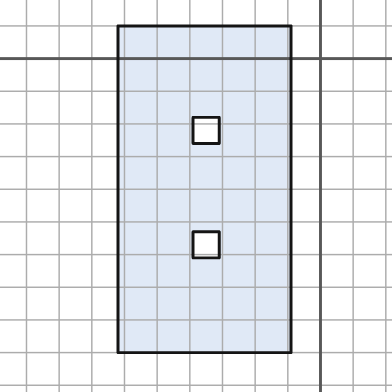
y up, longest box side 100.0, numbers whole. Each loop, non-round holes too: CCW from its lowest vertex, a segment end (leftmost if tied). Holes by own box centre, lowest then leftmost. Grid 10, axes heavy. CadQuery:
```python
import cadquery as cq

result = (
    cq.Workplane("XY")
    .moveTo(-62.0, -90.0)
    .lineTo(-9.0, -90.0)
    .lineTo(-9.0, 10.0)
    .lineTo(-62.0, 10.0)
    .close()
    .moveTo(-39.0, -61.0)
    .lineTo(-31.0, -61.0)
    .lineTo(-31.0, -53.0)
    .lineTo(-39.0, -53.0)
    .close()
    .moveTo(-39.0, -26.0)
    .lineTo(-31.0, -26.0)
    .lineTo(-31.0, -18.0)
    .lineTo(-39.0, -18.0)
    .close()
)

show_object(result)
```